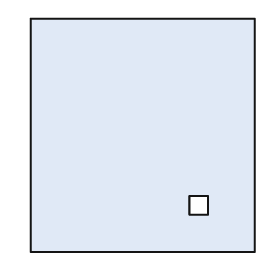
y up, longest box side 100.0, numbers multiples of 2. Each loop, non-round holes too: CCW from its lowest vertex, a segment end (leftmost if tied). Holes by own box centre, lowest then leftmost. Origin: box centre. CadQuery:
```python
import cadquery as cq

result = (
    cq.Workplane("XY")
    .moveTo(-48.0, -50.0)
    .lineTo(48.0, -50.0)
    .lineTo(48.0, 50.0)
    .lineTo(-48.0, 50.0)
    .close()
    .moveTo(20.0, -34.0)
    .lineTo(28.0, -34.0)
    .lineTo(28.0, -26.0)
    .lineTo(20.0, -26.0)
    .close()
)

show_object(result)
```